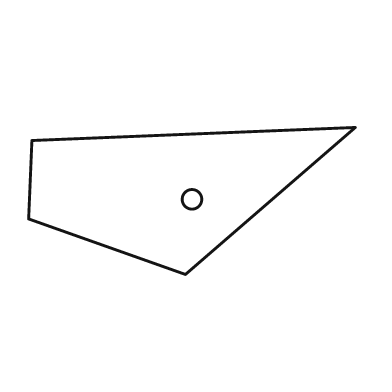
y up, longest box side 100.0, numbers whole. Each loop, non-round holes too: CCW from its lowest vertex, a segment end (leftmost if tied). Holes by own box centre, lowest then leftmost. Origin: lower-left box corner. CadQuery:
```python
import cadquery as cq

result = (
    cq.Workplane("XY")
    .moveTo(48.0, 0.0)
    .lineTo(100.0, 45.0)
    .lineTo(1.0, 41.0)
    .lineTo(0.0, 17.0)
    .close()
    .moveTo(50.0, 23.0)
    .circle(3.0)
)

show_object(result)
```